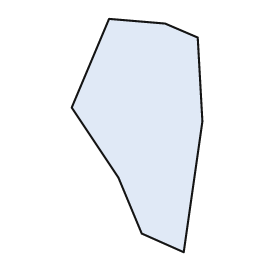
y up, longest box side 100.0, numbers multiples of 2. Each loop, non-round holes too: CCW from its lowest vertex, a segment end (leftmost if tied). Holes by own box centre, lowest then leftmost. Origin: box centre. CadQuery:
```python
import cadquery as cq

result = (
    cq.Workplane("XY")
    .moveTo(20.0, -50.0)
    .lineTo(28.0, 6.0)
    .lineTo(26.0, 42.0)
    .lineTo(12.0, 48.0)
    .lineTo(-12.0, 50.0)
    .lineTo(-28.0, 12.0)
    .lineTo(-8.0, -18.0)
    .lineTo(2.0, -42.0)
    .close()
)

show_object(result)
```